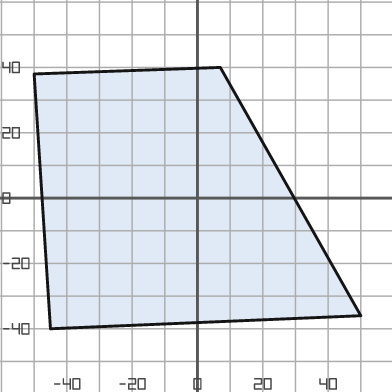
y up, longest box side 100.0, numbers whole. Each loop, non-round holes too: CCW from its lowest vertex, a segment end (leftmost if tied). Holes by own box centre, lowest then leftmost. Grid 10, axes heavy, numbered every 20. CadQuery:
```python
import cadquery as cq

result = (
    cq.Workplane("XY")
    .moveTo(-45.0, -40.0)
    .lineTo(50.0, -36.0)
    .lineTo(7.0, 40.0)
    .lineTo(-50.0, 38.0)
    .close()
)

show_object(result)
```